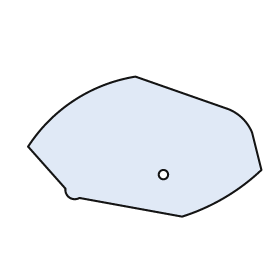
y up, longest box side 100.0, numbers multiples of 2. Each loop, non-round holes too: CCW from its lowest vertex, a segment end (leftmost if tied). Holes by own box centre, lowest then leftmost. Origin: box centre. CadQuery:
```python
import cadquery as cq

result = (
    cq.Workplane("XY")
    .moveTo(16.0, -30.0)
    .threePointArc((34.0, -22.0), (50.0, -10.0))
    .lineTo(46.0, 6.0)
    .threePointArc((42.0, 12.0), (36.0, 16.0))
    .lineTo(-4.0, 30.0)
    .threePointArc((-30.0, 20.0), (-50.0, 0.0))
    .lineTo(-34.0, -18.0)
    .threePointArc((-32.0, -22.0), (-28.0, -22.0))
    .close()
    .moveTo(8.0, -12.0)
    .circle(2.0)
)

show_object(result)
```